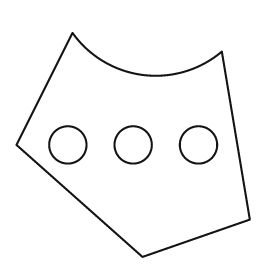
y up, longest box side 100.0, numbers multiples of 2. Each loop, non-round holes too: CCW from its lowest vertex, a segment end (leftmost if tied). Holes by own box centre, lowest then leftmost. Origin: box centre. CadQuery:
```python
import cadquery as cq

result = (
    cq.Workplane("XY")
    .moveTo(4.0, -48.0)
    .lineTo(50.0, -32.0)
    .lineTo(38.0, 40.0)
    .threePointArc((4.0, 30.0), (-26.0, 48.0))
    .lineTo(-50.0, 0.0)
    .close()
    .moveTo(-28.0, 0.0)
    .circle(8.0)
    .moveTo(0.0, 0.0)
    .circle(8.0)
    .moveTo(28.0, 0.0)
    .circle(8.0)
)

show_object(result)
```